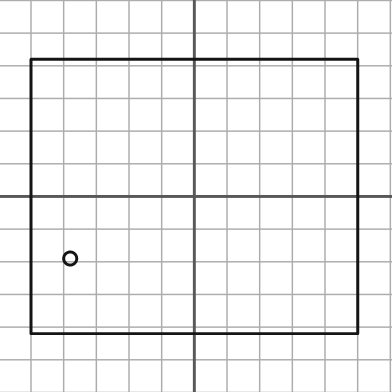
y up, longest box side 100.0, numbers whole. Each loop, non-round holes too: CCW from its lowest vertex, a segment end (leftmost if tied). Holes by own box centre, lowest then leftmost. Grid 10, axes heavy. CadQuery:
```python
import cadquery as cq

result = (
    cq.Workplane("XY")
    .moveTo(-50.0, -42.0)
    .lineTo(50.0, -42.0)
    .lineTo(50.0, 42.0)
    .lineTo(-50.0, 42.0)
    .close()
    .moveTo(-38.0, -19.0)
    .circle(2.0)
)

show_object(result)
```